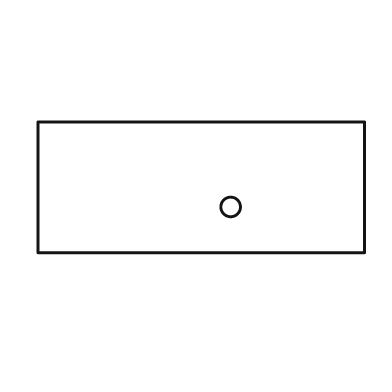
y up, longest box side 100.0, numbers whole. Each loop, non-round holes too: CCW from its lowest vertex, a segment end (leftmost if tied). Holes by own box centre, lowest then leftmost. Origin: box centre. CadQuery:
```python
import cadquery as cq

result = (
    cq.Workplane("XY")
    .moveTo(-50.0, -20.0)
    .lineTo(50.0, -20.0)
    .lineTo(50.0, 20.0)
    .lineTo(-50.0, 20.0)
    .close()
    .moveTo(9.0, -6.0)
    .circle(3.0)
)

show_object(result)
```